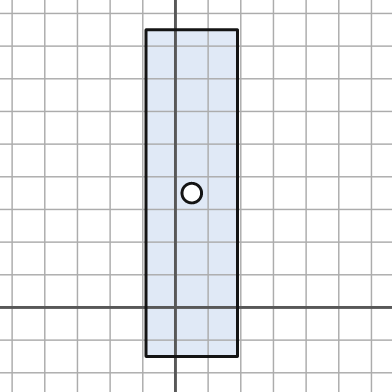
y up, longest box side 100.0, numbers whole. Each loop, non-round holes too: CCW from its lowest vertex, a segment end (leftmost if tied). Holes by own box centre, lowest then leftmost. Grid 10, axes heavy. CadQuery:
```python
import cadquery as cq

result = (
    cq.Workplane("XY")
    .moveTo(-9.0, -15.0)
    .lineTo(19.0, -15.0)
    .lineTo(19.0, 85.0)
    .lineTo(-9.0, 85.0)
    .close()
    .moveTo(5.0, 35.0)
    .circle(3.0)
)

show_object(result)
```